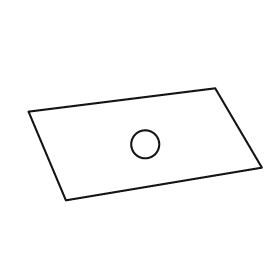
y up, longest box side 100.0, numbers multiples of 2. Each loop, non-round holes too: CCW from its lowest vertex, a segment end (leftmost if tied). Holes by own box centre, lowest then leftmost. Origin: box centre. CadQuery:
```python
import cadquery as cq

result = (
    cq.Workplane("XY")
    .moveTo(-34.0, -24.0)
    .lineTo(50.0, -10.0)
    .lineTo(30.0, 24.0)
    .lineTo(-50.0, 14.0)
    .close()
    .moveTo(0.0, 0.0)
    .circle(6.0)
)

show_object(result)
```